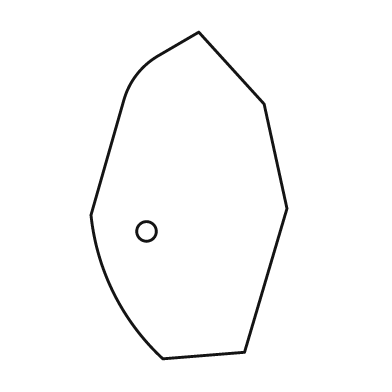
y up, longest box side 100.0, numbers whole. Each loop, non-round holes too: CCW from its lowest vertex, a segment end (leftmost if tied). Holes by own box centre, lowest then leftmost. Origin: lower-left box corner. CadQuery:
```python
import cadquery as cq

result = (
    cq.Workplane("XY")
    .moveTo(22.0, 0.0)
    .lineTo(47.0, 2.0)
    .lineTo(60.0, 46.0)
    .lineTo(53.0, 78.0)
    .lineTo(33.0, 100.0)
    .lineTo(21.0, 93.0)
    .threePointArc((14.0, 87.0), (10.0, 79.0))
    .lineTo(0.0, 44.0)
    .threePointArc((7.0, 20.0), (22.0, 0.0))
    .close()
    .moveTo(17.0, 39.0)
    .circle(3.0)
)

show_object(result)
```